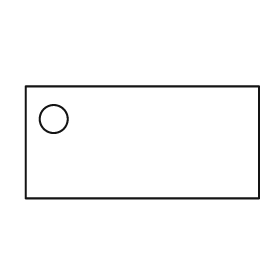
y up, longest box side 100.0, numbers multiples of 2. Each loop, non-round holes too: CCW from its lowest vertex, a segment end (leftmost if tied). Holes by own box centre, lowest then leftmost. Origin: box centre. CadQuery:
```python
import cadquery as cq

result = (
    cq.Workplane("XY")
    .moveTo(-50.0, -24.0)
    .lineTo(50.0, -24.0)
    .lineTo(50.0, 24.0)
    .lineTo(-50.0, 24.0)
    .close()
    .moveTo(-38.0, 10.0)
    .circle(6.0)
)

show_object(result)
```